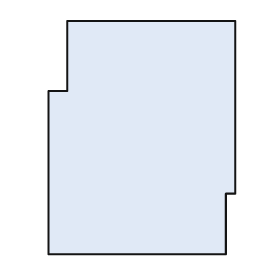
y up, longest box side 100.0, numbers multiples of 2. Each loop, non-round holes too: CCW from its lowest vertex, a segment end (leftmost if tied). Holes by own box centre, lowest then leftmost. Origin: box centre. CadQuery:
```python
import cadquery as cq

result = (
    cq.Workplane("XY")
    .moveTo(-40.0, -50.0)
    .lineTo(36.0, -50.0)
    .lineTo(36.0, -24.0)
    .lineTo(40.0, -24.0)
    .lineTo(40.0, 50.0)
    .lineTo(-32.0, 50.0)
    .lineTo(-32.0, 20.0)
    .lineTo(-40.0, 20.0)
    .close()
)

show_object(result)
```